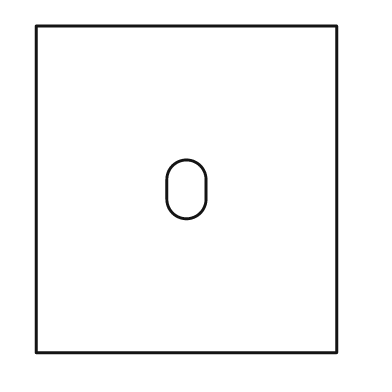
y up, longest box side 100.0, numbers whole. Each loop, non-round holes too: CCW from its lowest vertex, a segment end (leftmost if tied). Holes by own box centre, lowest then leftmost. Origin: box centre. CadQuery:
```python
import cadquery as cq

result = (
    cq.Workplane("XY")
    .moveTo(-46.0, -50.0)
    .lineTo(46.0, -50.0)
    .lineTo(46.0, 50.0)
    .lineTo(-46.0, 50.0)
    .close()
    .moveTo(-6.0, -3.0)
    .threePointArc((0.0, -9.0), (6.0, -3.0))
    .lineTo(6.0, 3.0)
    .threePointArc((0.0, 9.0), (-6.0, 3.0))
    .close()
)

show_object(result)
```